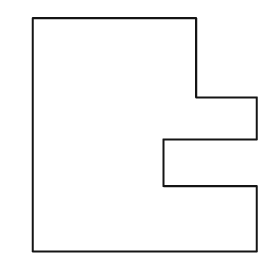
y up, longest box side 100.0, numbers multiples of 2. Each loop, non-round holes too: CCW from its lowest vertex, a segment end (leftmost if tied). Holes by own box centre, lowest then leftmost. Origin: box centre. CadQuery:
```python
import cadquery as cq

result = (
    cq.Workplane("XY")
    .moveTo(-48.0, -50.0)
    .lineTo(48.0, -50.0)
    .lineTo(48.0, -22.0)
    .lineTo(8.0, -22.0)
    .lineTo(8.0, -2.0)
    .lineTo(48.0, -2.0)
    .lineTo(48.0, 16.0)
    .lineTo(22.0, 16.0)
    .lineTo(22.0, 50.0)
    .lineTo(-48.0, 50.0)
    .close()
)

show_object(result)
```